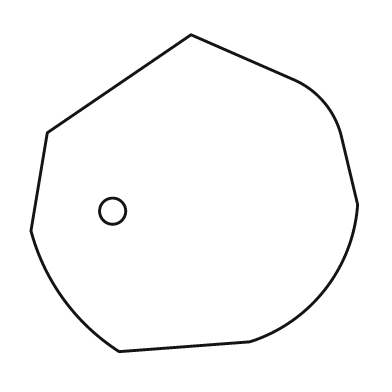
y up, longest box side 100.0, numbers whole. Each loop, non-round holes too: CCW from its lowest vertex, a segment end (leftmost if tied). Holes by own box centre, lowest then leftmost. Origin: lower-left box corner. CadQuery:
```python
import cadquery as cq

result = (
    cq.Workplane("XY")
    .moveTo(27.0, 0.0)
    .lineTo(67.0, 3.0)
    .threePointArc((90.0, 19.0), (100.0, 45.0))
    .lineTo(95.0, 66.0)
    .threePointArc((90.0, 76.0), (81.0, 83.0))
    .lineTo(49.0, 97.0)
    .lineTo(5.0, 67.0)
    .lineTo(0.0, 37.0)
    .threePointArc((10.0, 16.0), (27.0, 0.0))
    .close()
    .moveTo(25.0, 43.0)
    .circle(4.0)
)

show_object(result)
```